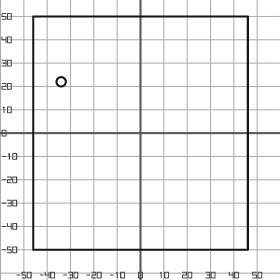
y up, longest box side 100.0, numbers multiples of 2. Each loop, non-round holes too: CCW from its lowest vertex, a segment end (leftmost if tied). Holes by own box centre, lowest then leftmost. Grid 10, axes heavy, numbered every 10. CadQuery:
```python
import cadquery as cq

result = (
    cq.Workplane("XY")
    .moveTo(-46.0, -50.0)
    .lineTo(46.0, -50.0)
    .lineTo(46.0, 50.0)
    .lineTo(-46.0, 50.0)
    .close()
    .moveTo(-34.0, 22.0)
    .circle(2.0)
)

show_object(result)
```